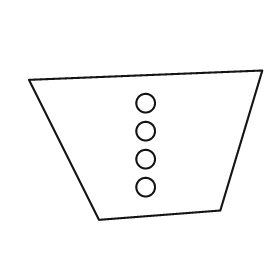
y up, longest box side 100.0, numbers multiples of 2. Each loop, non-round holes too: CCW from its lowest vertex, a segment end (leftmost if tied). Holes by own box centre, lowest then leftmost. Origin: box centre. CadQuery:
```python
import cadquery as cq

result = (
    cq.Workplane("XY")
    .moveTo(-20.0, -32.0)
    .lineTo(32.0, -28.0)
    .lineTo(50.0, 32.0)
    .lineTo(-50.0, 28.0)
    .close()
    .moveTo(0.0, -18.0)
    .circle(4.0)
    .moveTo(0.0, -6.0)
    .circle(4.0)
    .moveTo(0.0, 6.0)
    .circle(4.0)
    .moveTo(0.0, 18.0)
    .circle(4.0)
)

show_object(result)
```